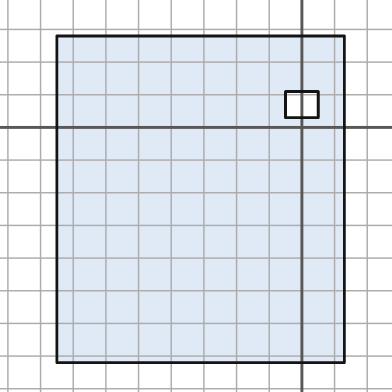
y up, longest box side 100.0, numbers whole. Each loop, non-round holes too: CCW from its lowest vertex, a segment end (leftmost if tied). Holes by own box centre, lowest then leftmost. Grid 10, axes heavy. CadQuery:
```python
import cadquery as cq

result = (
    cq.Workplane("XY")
    .moveTo(-75.0, -72.0)
    .lineTo(13.0, -72.0)
    .lineTo(13.0, 28.0)
    .lineTo(-75.0, 28.0)
    .close()
    .moveTo(-5.0, 3.0)
    .lineTo(5.0, 3.0)
    .lineTo(5.0, 11.0)
    .lineTo(-5.0, 11.0)
    .close()
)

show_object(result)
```